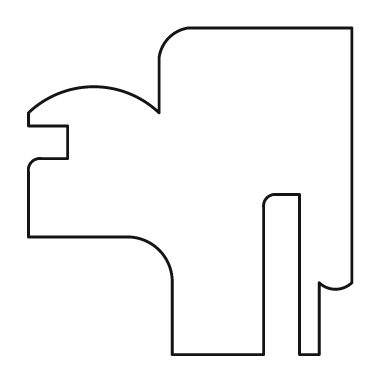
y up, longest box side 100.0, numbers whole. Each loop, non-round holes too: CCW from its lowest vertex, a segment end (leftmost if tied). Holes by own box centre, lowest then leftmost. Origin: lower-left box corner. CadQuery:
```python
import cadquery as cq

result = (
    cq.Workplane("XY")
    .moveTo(44.0, 0.0)
    .lineTo(72.0, 0.0)
    .lineTo(72.0, 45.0)
    .threePointArc((73.0, 48.0), (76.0, 49.0))
    .lineTo(83.0, 49.0)
    .lineTo(83.0, 0.0)
    .lineTo(89.0, 0.0)
    .lineTo(89.0, 22.0)
    .threePointArc((94.0, 20.0), (99.0, 22.0))
    .lineTo(99.0, 100.0)
    .lineTo(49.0, 100.0)
    .threePointArc((43.0, 97.0), (40.0, 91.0))
    .lineTo(40.0, 74.0)
    .threePointArc((20.0, 82.0), (0.0, 74.0))
    .lineTo(0.0, 70.0)
    .lineTo(12.0, 70.0)
    .lineTo(12.0, 60.0)
    .lineTo(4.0, 60.0)
    .threePointArc((1.0, 59.0), (0.0, 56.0))
    .lineTo(0.0, 36.0)
    .lineTo(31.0, 36.0)
    .threePointArc((40.0, 32.0), (44.0, 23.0))
    .close()
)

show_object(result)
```